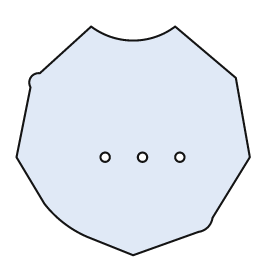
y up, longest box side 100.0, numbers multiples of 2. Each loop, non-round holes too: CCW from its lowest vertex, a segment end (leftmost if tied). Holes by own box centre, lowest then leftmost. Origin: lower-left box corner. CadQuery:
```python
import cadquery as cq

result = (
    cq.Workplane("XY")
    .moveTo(50.0, 0.0)
    .lineTo(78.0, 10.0)
    .threePointArc((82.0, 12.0), (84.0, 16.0))
    .lineTo(100.0, 42.0)
    .lineTo(94.0, 76.0)
    .lineTo(68.0, 98.0)
    .threePointArc((50.0, 92.0), (32.0, 98.0))
    .lineTo(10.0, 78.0)
    .threePointArc((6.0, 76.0), (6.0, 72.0))
    .lineTo(0.0, 42.0)
    .lineTo(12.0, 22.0)
    .threePointArc((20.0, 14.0), (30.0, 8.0))
    .close()
    .moveTo(38.0, 42.0)
    .circle(2.0)
    .moveTo(54.0, 42.0)
    .circle(2.0)
    .moveTo(70.0, 42.0)
    .circle(2.0)
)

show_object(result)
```